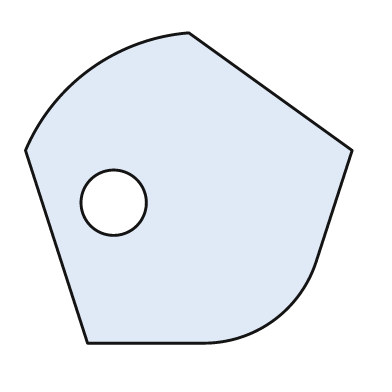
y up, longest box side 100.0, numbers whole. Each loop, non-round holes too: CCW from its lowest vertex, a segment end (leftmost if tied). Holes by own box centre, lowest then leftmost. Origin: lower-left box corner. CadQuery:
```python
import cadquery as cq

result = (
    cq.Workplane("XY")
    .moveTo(19.0, 0.0)
    .lineTo(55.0, 0.0)
    .threePointArc((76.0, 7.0), (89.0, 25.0))
    .lineTo(100.0, 59.0)
    .lineTo(50.0, 95.0)
    .threePointArc((20.0, 84.0), (0.0, 59.0))
    .close()
    .moveTo(27.0, 43.0)
    .circle(10.0)
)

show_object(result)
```